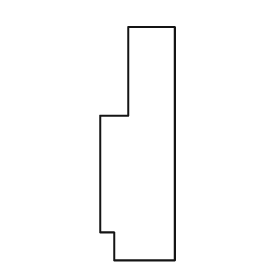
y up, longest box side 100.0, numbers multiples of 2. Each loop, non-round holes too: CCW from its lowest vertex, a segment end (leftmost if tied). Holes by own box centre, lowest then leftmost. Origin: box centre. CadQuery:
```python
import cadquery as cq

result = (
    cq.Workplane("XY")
    .moveTo(-10.0, -50.0)
    .lineTo(16.0, -50.0)
    .lineTo(16.0, 50.0)
    .lineTo(-4.0, 50.0)
    .lineTo(-4.0, 12.0)
    .lineTo(-16.0, 12.0)
    .lineTo(-16.0, -38.0)
    .lineTo(-10.0, -38.0)
    .close()
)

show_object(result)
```